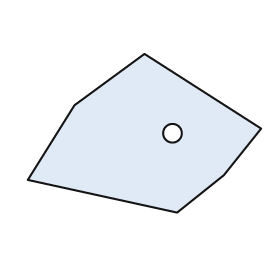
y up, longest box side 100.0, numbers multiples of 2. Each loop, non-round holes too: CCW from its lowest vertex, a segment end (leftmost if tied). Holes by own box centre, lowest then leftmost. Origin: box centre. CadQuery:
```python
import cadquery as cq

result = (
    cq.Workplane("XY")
    .moveTo(14.0, -34.0)
    .lineTo(34.0, -18.0)
    .lineTo(50.0, 2.0)
    .lineTo(0.0, 34.0)
    .lineTo(-30.0, 12.0)
    .lineTo(-50.0, -20.0)
    .close()
    .moveTo(12.0, 0.0)
    .circle(4.0)
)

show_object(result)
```